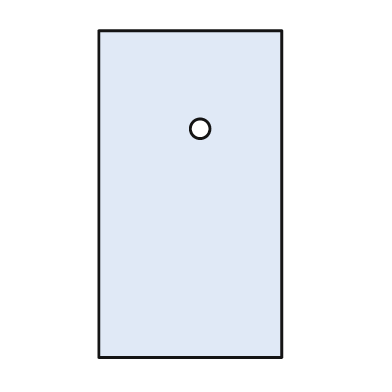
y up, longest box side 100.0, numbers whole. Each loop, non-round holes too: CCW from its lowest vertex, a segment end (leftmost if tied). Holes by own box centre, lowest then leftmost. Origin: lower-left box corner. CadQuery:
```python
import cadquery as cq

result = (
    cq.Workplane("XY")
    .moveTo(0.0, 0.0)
    .lineTo(56.0, 0.0)
    .lineTo(56.0, 100.0)
    .lineTo(0.0, 100.0)
    .close()
    .moveTo(31.0, 70.0)
    .circle(3.0)
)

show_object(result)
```